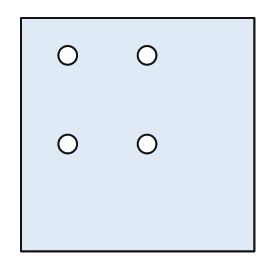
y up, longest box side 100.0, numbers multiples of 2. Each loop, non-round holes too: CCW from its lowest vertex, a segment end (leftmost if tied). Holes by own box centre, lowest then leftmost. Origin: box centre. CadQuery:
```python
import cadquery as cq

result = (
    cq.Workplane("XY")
    .moveTo(-50.0, -50.0)
    .lineTo(50.0, -50.0)
    .lineTo(50.0, 50.0)
    .lineTo(-50.0, 50.0)
    .close()
    .moveTo(-30.0, -4.0)
    .circle(4.0)
    .moveTo(4.0, -4.0)
    .circle(4.0)
    .moveTo(-30.0, 34.0)
    .circle(4.0)
    .moveTo(4.0, 34.0)
    .circle(4.0)
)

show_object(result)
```